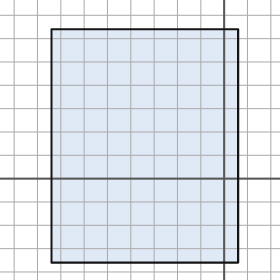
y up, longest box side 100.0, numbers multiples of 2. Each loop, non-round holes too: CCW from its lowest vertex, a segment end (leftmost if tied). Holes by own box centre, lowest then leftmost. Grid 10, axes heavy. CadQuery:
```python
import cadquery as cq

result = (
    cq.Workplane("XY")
    .moveTo(-74.0, -36.0)
    .lineTo(6.0, -36.0)
    .lineTo(6.0, 64.0)
    .lineTo(-74.0, 64.0)
    .close()
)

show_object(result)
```